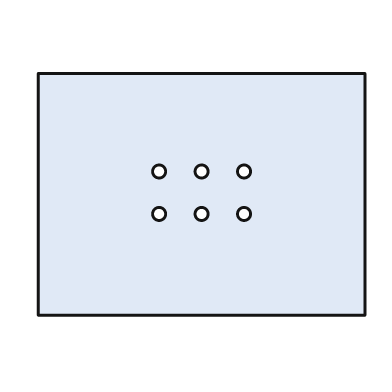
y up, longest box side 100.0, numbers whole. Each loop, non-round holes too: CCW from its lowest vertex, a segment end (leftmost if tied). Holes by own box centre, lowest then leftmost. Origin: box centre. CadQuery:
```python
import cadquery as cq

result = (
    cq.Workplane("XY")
    .moveTo(-50.0, -37.0)
    .lineTo(50.0, -37.0)
    .lineTo(50.0, 37.0)
    .lineTo(-50.0, 37.0)
    .close()
    .moveTo(-13.0, -6.0)
    .circle(2.0)
    .moveTo(0.0, -6.0)
    .circle(2.0)
    .moveTo(13.0, -6.0)
    .circle(2.0)
    .moveTo(-13.0, 7.0)
    .circle(2.0)
    .moveTo(0.0, 7.0)
    .circle(2.0)
    .moveTo(13.0, 7.0)
    .circle(2.0)
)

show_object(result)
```